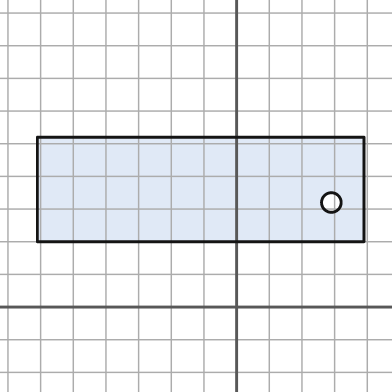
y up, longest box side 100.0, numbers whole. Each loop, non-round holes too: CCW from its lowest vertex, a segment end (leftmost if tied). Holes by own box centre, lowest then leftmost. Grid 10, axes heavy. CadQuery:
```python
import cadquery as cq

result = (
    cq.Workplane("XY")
    .moveTo(-61.0, 20.0)
    .lineTo(39.0, 20.0)
    .lineTo(39.0, 52.0)
    .lineTo(-61.0, 52.0)
    .close()
    .moveTo(29.0, 32.0)
    .circle(3.0)
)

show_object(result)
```